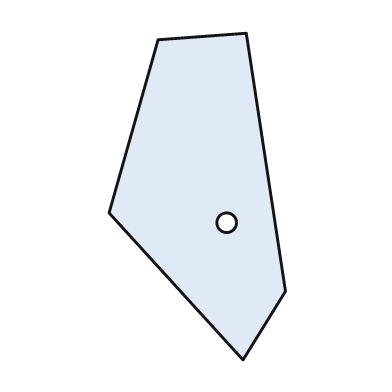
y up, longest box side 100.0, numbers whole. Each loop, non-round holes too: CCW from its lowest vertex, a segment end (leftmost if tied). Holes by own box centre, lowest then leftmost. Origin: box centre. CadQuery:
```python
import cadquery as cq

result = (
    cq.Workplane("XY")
    .moveTo(14.0, -50.0)
    .lineTo(27.0, -29.0)
    .lineTo(15.0, 50.0)
    .lineTo(-12.0, 48.0)
    .lineTo(-27.0, -5.0)
    .close()
    .moveTo(9.0, -8.0)
    .circle(3.0)
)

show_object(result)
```